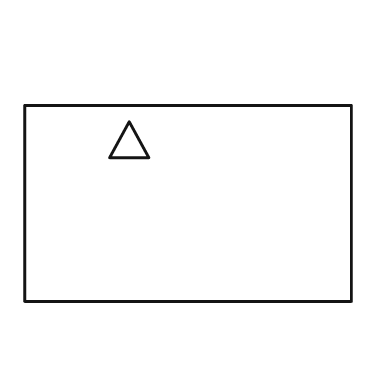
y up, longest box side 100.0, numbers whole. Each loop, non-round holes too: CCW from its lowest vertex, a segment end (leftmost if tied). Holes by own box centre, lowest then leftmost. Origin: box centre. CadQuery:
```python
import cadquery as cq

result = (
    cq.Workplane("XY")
    .moveTo(-50.0, -30.0)
    .lineTo(50.0, -30.0)
    .lineTo(50.0, 30.0)
    .lineTo(-50.0, 30.0)
    .close()
    .moveTo(-24.0, 14.0)
    .lineTo(-12.0, 14.0)
    .lineTo(-18.0, 25.0)
    .close()
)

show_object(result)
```